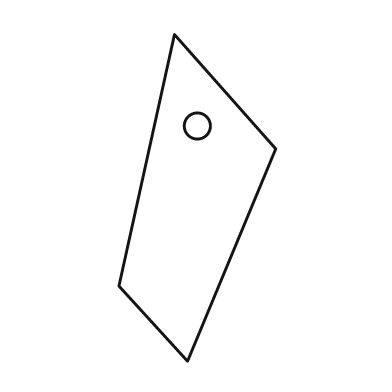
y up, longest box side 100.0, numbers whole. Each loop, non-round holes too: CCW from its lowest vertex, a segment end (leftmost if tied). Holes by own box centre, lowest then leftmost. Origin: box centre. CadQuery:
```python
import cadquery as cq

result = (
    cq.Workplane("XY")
    .moveTo(-3.0, -50.0)
    .lineTo(24.0, 15.0)
    .lineTo(-7.0, 50.0)
    .lineTo(-24.0, -27.0)
    .close()
    .moveTo(0.0, 22.0)
    .circle(4.0)
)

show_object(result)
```